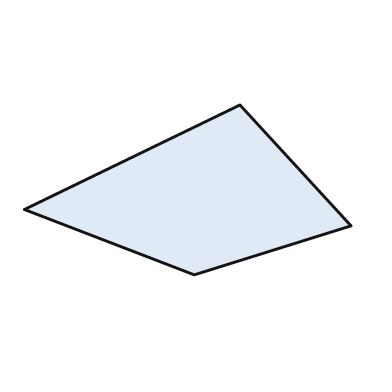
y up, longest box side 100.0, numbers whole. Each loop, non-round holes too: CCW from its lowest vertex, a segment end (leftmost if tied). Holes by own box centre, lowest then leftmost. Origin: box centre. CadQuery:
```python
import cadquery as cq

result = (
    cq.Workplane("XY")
    .moveTo(2.0, -26.0)
    .lineTo(50.0, -11.0)
    .lineTo(16.0, 26.0)
    .lineTo(-50.0, -6.0)
    .close()
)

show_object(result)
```